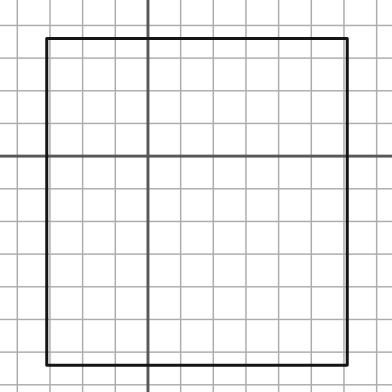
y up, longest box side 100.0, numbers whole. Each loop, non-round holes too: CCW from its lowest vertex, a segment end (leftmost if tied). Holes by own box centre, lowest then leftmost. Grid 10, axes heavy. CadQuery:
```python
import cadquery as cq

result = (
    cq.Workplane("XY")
    .moveTo(-31.0, -64.0)
    .lineTo(61.0, -64.0)
    .lineTo(61.0, 36.0)
    .lineTo(-31.0, 36.0)
    .close()
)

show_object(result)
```